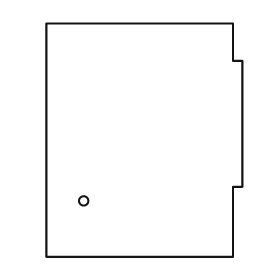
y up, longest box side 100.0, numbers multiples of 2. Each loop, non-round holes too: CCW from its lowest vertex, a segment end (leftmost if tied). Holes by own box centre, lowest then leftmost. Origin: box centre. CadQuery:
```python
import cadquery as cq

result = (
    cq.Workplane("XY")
    .moveTo(-42.0, -50.0)
    .lineTo(38.0, -50.0)
    .lineTo(38.0, -20.0)
    .lineTo(42.0, -20.0)
    .lineTo(42.0, 34.0)
    .lineTo(38.0, 34.0)
    .lineTo(38.0, 50.0)
    .lineTo(-42.0, 50.0)
    .close()
    .moveTo(-26.0, -26.0)
    .circle(2.0)
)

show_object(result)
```